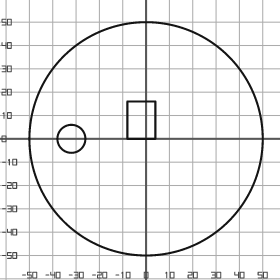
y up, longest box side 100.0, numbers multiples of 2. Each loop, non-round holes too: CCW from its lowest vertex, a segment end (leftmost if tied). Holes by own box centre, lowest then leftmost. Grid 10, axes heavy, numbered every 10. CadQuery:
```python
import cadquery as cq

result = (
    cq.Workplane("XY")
    .moveTo(0.0, 0.0)
    .circle(50.0)
    .moveTo(-32.0, 0.0)
    .circle(6.0)
    .moveTo(-8.0, 0.0)
    .lineTo(4.0, 0.0)
    .lineTo(4.0, 16.0)
    .lineTo(-8.0, 16.0)
    .close()
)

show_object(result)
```